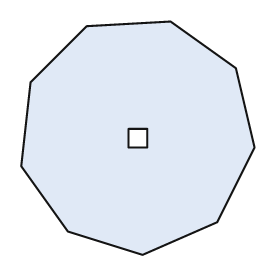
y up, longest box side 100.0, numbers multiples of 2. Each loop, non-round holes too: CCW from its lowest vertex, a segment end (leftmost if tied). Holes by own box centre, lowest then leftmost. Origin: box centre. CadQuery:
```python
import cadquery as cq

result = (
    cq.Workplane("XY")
    .moveTo(2.0, -50.0)
    .lineTo(34.0, -36.0)
    .lineTo(50.0, -4.0)
    .lineTo(42.0, 30.0)
    .lineTo(14.0, 50.0)
    .lineTo(-22.0, 48.0)
    .lineTo(-46.0, 24.0)
    .lineTo(-50.0, -12.0)
    .lineTo(-30.0, -40.0)
    .close()
    .moveTo(-4.0, -4.0)
    .lineTo(4.0, -4.0)
    .lineTo(4.0, 4.0)
    .lineTo(-4.0, 4.0)
    .close()
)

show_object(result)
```